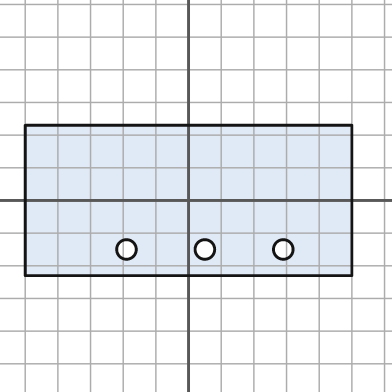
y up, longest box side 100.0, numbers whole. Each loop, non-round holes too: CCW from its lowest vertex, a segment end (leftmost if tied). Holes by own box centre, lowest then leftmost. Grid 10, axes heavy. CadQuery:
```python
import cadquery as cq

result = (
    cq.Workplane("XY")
    .moveTo(-50.0, -23.0)
    .lineTo(50.0, -23.0)
    .lineTo(50.0, 23.0)
    .lineTo(-50.0, 23.0)
    .close()
    .moveTo(-19.0, -15.0)
    .circle(3.0)
    .moveTo(5.0, -15.0)
    .circle(3.0)
    .moveTo(29.0, -15.0)
    .circle(3.0)
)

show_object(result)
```